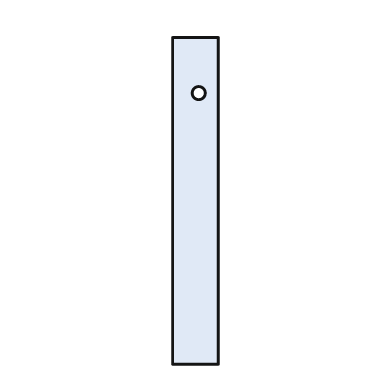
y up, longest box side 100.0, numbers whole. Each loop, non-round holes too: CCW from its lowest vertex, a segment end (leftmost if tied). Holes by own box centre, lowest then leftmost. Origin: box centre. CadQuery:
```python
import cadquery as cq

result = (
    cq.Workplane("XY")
    .moveTo(-7.0, -50.0)
    .lineTo(7.0, -50.0)
    .lineTo(7.0, 50.0)
    .lineTo(-7.0, 50.0)
    .close()
    .moveTo(1.0, 33.0)
    .circle(2.0)
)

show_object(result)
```